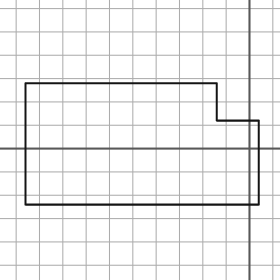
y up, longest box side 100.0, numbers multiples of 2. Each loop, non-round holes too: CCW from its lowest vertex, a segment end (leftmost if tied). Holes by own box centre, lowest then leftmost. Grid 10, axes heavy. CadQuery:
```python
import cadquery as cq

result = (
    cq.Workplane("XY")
    .moveTo(-96.0, -24.0)
    .lineTo(4.0, -24.0)
    .lineTo(4.0, 12.0)
    .lineTo(-14.0, 12.0)
    .lineTo(-14.0, 28.0)
    .lineTo(-96.0, 28.0)
    .close()
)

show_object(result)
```